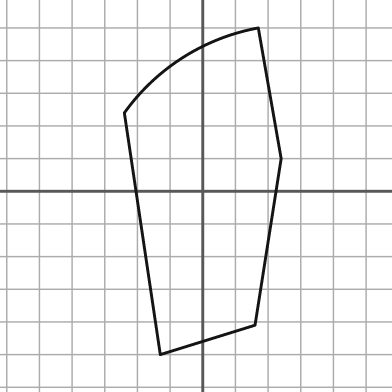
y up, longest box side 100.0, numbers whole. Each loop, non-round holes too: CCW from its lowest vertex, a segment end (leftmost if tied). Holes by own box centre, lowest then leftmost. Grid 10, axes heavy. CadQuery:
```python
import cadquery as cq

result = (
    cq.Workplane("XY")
    .moveTo(-13.0, -50.0)
    .lineTo(16.0, -41.0)
    .lineTo(24.0, 10.0)
    .lineTo(17.0, 50.0)
    .threePointArc((-6.0, 41.0), (-24.0, 24.0))
    .close()
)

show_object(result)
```